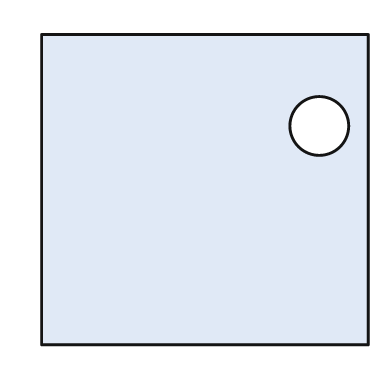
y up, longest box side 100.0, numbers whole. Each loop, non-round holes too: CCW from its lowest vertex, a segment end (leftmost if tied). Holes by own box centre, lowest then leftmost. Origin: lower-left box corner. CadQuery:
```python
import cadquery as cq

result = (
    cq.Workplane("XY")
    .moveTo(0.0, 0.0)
    .lineTo(100.0, 0.0)
    .lineTo(100.0, 95.0)
    .lineTo(0.0, 95.0)
    .close()
    .moveTo(85.0, 67.0)
    .circle(9.0)
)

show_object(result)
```